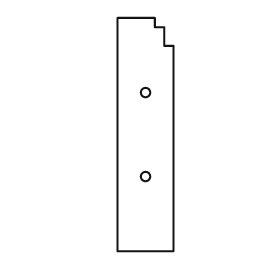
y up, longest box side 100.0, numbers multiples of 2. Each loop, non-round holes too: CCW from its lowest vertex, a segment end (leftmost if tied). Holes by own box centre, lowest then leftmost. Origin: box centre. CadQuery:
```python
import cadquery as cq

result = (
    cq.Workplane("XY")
    .moveTo(-12.0, -50.0)
    .lineTo(12.0, -50.0)
    .lineTo(12.0, 38.0)
    .lineTo(8.0, 38.0)
    .lineTo(8.0, 46.0)
    .lineTo(4.0, 46.0)
    .lineTo(4.0, 50.0)
    .lineTo(-12.0, 50.0)
    .close()
    .moveTo(0.0, -18.0)
    .circle(2.0)
    .moveTo(0.0, 18.0)
    .circle(2.0)
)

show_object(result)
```